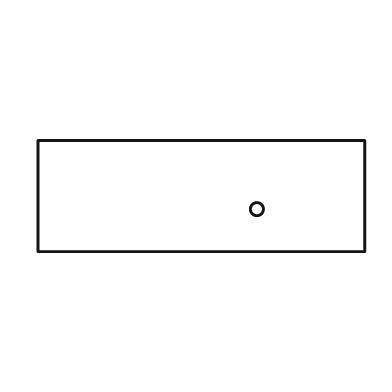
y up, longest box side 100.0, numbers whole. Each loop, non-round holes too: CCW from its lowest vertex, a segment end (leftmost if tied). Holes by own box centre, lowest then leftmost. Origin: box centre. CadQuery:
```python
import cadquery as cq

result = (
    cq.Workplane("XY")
    .moveTo(-50.0, -17.0)
    .lineTo(50.0, -17.0)
    .lineTo(50.0, 17.0)
    .lineTo(-50.0, 17.0)
    .close()
    .moveTo(17.0, -4.0)
    .circle(2.0)
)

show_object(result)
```